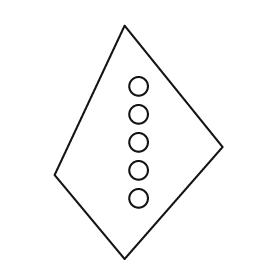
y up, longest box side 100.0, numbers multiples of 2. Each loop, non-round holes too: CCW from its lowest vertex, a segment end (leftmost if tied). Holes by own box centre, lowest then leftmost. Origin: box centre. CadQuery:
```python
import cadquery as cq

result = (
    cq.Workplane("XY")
    .moveTo(-6.0, -50.0)
    .lineTo(36.0, -2.0)
    .lineTo(-6.0, 50.0)
    .lineTo(-36.0, -14.0)
    .close()
    .moveTo(0.0, -24.0)
    .circle(4.0)
    .moveTo(0.0, -12.0)
    .circle(4.0)
    .moveTo(0.0, 0.0)
    .circle(4.0)
    .moveTo(0.0, 12.0)
    .circle(4.0)
    .moveTo(0.0, 24.0)
    .circle(4.0)
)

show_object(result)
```